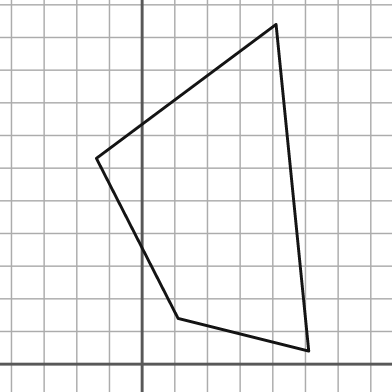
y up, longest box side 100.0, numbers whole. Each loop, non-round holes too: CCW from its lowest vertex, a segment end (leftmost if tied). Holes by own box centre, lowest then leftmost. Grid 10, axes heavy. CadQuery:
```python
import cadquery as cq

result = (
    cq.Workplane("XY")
    .moveTo(51.0, 4.0)
    .lineTo(41.0, 104.0)
    .lineTo(-14.0, 63.0)
    .lineTo(11.0, 14.0)
    .close()
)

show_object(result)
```